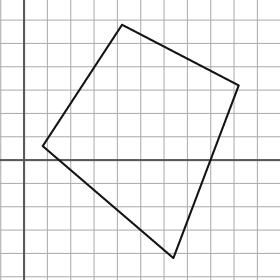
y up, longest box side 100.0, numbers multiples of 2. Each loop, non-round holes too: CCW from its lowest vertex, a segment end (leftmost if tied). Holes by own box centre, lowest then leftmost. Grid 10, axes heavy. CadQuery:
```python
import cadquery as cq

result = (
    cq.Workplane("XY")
    .moveTo(64.0, -42.0)
    .lineTo(92.0, 32.0)
    .lineTo(42.0, 58.0)
    .lineTo(8.0, 6.0)
    .close()
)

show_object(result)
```